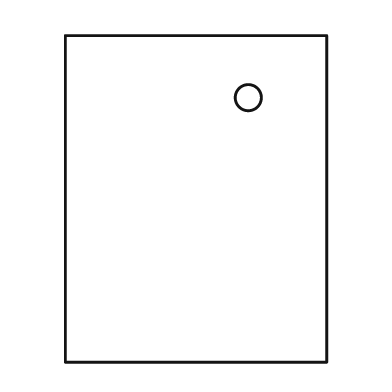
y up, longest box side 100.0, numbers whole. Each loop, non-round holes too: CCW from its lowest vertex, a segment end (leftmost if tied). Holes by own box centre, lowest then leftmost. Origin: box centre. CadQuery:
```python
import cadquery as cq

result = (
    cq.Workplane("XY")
    .moveTo(-40.0, -50.0)
    .lineTo(40.0, -50.0)
    .lineTo(40.0, 50.0)
    .lineTo(-40.0, 50.0)
    .close()
    .moveTo(16.0, 31.0)
    .circle(4.0)
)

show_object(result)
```